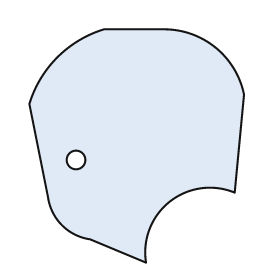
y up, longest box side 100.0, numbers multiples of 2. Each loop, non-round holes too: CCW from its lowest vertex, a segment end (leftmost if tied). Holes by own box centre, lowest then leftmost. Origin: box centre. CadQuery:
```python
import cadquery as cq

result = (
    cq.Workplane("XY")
    .moveTo(4.0, -50.0)
    .threePointArc((14.0, -24.0), (42.0, -20.0))
    .lineTo(46.0, 22.0)
    .threePointArc((34.0, 42.0), (12.0, 50.0))
    .lineTo(-14.0, 50.0)
    .threePointArc((-34.0, 38.0), (-46.0, 18.0))
    .lineTo(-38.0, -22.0)
    .threePointArc((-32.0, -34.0), (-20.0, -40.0))
    .close()
    .moveTo(-26.0, -6.0)
    .circle(4.0)
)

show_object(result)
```